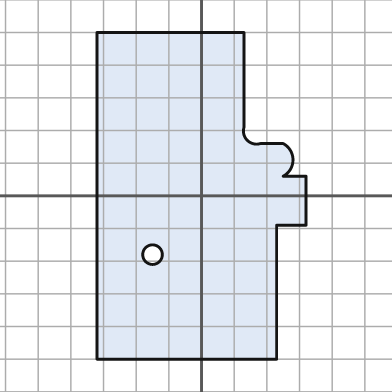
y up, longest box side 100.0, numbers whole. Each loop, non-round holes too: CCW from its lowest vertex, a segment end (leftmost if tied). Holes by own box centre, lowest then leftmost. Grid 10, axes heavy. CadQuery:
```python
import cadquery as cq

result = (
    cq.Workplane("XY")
    .moveTo(-32.0, -50.0)
    .lineTo(23.0, -50.0)
    .lineTo(23.0, -9.0)
    .lineTo(32.0, -9.0)
    .lineTo(32.0, 6.0)
    .lineTo(25.0, 6.0)
    .threePointArc((28.0, 11.0), (25.0, 16.0))
    .lineTo(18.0, 16.0)
    .threePointArc((14.0, 17.0), (13.0, 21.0))
    .lineTo(13.0, 50.0)
    .lineTo(-32.0, 50.0)
    .close()
    .moveTo(-15.0, -18.0)
    .circle(3.0)
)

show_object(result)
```